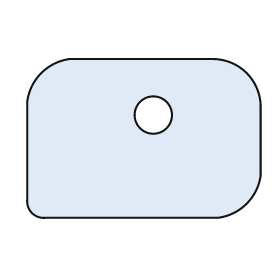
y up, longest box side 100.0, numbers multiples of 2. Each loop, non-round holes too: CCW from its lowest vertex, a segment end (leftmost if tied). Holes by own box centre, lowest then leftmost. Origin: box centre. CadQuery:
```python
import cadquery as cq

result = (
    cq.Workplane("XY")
    .moveTo(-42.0, -34.0)
    .lineTo(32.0, -34.0)
    .threePointArc((44.0, -28.0), (50.0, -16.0))
    .lineTo(50.0, 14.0)
    .threePointArc((44.0, 28.0), (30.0, 34.0))
    .lineTo(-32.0, 34.0)
    .threePointArc((-44.0, 28.0), (-50.0, 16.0))
    .lineTo(-50.0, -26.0)
    .threePointArc((-48.0, -32.0), (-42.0, -34.0))
    .close()
    .moveTo(4.0, 10.0)
    .circle(8.0)
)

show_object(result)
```